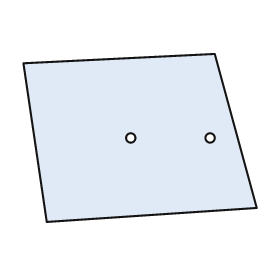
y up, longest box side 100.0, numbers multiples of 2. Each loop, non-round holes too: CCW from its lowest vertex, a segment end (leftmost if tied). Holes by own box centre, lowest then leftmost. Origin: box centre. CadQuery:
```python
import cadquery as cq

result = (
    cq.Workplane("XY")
    .moveTo(-40.0, -36.0)
    .lineTo(50.0, -30.0)
    .lineTo(32.0, 36.0)
    .lineTo(-50.0, 32.0)
    .close()
    .moveTo(-4.0, 0.0)
    .circle(2.0)
    .moveTo(30.0, 0.0)
    .circle(2.0)
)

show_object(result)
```